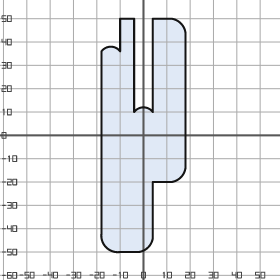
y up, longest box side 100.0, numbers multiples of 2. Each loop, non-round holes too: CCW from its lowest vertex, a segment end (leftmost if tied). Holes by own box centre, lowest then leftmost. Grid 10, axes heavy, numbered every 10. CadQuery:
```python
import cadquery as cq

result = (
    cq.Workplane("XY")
    .moveTo(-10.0, -50.0)
    .lineTo(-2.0, -50.0)
    .threePointArc((2.0, -48.0), (4.0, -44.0))
    .lineTo(4.0, -20.0)
    .lineTo(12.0, -20.0)
    .threePointArc((16.0, -18.0), (18.0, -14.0))
    .lineTo(18.0, 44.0)
    .threePointArc((16.0, 48.0), (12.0, 50.0))
    .lineTo(4.0, 50.0)
    .lineTo(4.0, 10.0)
    .threePointArc((0.0, 12.0), (-4.0, 10.0))
    .lineTo(-4.0, 50.0)
    .lineTo(-10.0, 50.0)
    .lineTo(-10.0, 36.0)
    .threePointArc((-14.0, 38.0), (-18.0, 36.0))
    .lineTo(-18.0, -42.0)
    .threePointArc((-16.0, -48.0), (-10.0, -50.0))
    .close()
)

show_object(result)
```